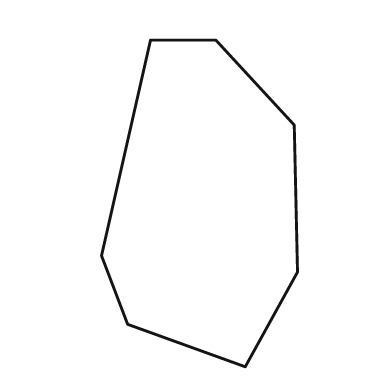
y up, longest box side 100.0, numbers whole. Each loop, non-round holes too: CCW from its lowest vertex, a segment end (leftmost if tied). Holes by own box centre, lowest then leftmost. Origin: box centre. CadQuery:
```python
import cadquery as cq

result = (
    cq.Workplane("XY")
    .moveTo(14.0, -50.0)
    .lineTo(30.0, -21.0)
    .lineTo(29.0, 24.0)
    .lineTo(5.0, 50.0)
    .lineTo(-15.0, 50.0)
    .lineTo(-30.0, -16.0)
    .lineTo(-22.0, -37.0)
    .close()
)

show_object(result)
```